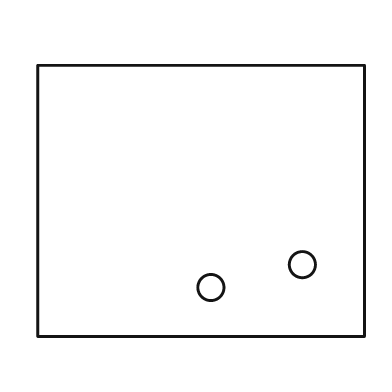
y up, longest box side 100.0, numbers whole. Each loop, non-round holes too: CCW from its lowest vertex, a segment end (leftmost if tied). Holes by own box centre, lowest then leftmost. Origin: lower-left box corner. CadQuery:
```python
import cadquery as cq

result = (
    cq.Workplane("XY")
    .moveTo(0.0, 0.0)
    .lineTo(100.0, 0.0)
    .lineTo(100.0, 83.0)
    .lineTo(0.0, 83.0)
    .close()
    .moveTo(53.0, 15.0)
    .circle(4.0)
    .moveTo(81.0, 22.0)
    .circle(4.0)
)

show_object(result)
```